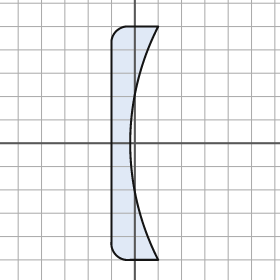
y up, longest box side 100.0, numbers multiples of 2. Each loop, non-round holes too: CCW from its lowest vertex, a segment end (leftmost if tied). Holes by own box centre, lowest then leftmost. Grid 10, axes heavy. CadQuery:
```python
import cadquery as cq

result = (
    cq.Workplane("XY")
    .moveTo(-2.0, -50.0)
    .lineTo(10.0, -50.0)
    .threePointArc((-2.0, 0.0), (10.0, 50.0))
    .lineTo(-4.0, 50.0)
    .threePointArc((-8.0, 48.0), (-10.0, 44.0))
    .lineTo(-10.0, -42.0)
    .threePointArc((-8.0, -48.0), (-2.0, -50.0))
    .close()
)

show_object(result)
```